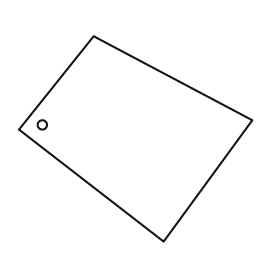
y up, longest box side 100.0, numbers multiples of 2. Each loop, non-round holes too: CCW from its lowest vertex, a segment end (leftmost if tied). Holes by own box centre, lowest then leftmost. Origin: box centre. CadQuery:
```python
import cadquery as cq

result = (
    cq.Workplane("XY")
    .moveTo(12.0, -44.0)
    .lineTo(50.0, 8.0)
    .lineTo(-18.0, 44.0)
    .lineTo(-50.0, 4.0)
    .close()
    .moveTo(-40.0, 6.0)
    .circle(2.0)
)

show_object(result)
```